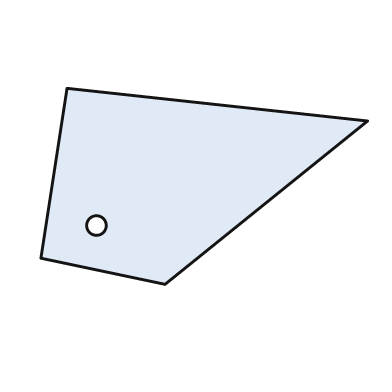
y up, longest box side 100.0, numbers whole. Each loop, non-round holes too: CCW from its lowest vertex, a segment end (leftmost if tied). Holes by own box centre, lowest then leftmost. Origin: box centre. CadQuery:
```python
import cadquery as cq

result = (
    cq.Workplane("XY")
    .moveTo(-12.0, -30.0)
    .lineTo(50.0, 20.0)
    .lineTo(-42.0, 30.0)
    .lineTo(-50.0, -22.0)
    .close()
    .moveTo(-33.0, -12.0)
    .circle(3.0)
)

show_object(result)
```